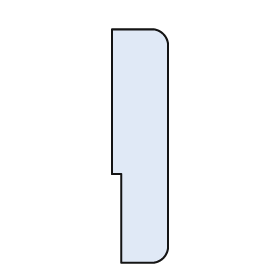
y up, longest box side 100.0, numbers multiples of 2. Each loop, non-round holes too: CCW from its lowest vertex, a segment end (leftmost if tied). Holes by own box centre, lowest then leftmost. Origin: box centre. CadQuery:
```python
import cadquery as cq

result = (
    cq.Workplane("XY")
    .moveTo(-8.0, -50.0)
    .lineTo(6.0, -50.0)
    .threePointArc((10.0, -48.0), (12.0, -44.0))
    .lineTo(12.0, 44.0)
    .threePointArc((10.0, 48.0), (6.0, 50.0))
    .lineTo(-12.0, 50.0)
    .lineTo(-12.0, -12.0)
    .lineTo(-8.0, -12.0)
    .close()
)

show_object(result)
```